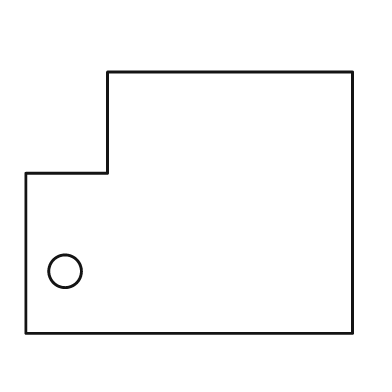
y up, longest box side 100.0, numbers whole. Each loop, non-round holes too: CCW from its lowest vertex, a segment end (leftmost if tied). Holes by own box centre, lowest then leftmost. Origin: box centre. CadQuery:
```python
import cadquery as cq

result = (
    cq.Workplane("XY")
    .moveTo(-50.0, -40.0)
    .lineTo(50.0, -40.0)
    .lineTo(50.0, 40.0)
    .lineTo(-25.0, 40.0)
    .lineTo(-25.0, 9.0)
    .lineTo(-50.0, 9.0)
    .close()
    .moveTo(-38.0, -21.0)
    .circle(5.0)
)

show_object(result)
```